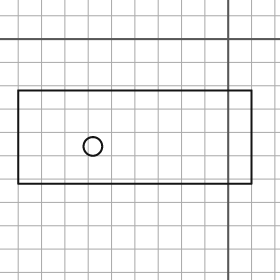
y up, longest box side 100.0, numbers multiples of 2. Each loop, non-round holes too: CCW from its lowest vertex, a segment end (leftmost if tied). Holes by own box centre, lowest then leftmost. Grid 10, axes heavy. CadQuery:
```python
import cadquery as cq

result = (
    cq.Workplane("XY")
    .moveTo(-90.0, -62.0)
    .lineTo(10.0, -62.0)
    .lineTo(10.0, -22.0)
    .lineTo(-90.0, -22.0)
    .close()
    .moveTo(-58.0, -46.0)
    .circle(4.0)
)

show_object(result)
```